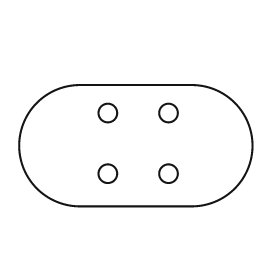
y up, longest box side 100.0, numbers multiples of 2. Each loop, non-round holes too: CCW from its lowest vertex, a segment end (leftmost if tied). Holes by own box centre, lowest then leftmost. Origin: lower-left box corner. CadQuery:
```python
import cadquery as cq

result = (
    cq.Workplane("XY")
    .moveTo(26.0, 0.0)
    .lineTo(74.0, 0.0)
    .threePointArc((100.0, 26.0), (74.0, 52.0))
    .lineTo(26.0, 52.0)
    .threePointArc((0.0, 26.0), (26.0, 0.0))
    .close()
    .moveTo(38.0, 14.0)
    .circle(4.0)
    .moveTo(64.0, 14.0)
    .circle(4.0)
    .moveTo(38.0, 40.0)
    .circle(4.0)
    .moveTo(64.0, 40.0)
    .circle(4.0)
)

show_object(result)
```